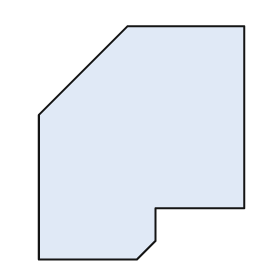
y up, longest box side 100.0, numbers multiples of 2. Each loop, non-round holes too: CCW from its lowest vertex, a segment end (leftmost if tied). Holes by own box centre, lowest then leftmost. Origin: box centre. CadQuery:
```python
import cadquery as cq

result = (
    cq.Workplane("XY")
    .moveTo(-44.0, -50.0)
    .lineTo(-2.0, -50.0)
    .lineTo(6.0, -42.0)
    .lineTo(6.0, -28.0)
    .lineTo(44.0, -28.0)
    .lineTo(44.0, 50.0)
    .lineTo(-6.0, 50.0)
    .lineTo(-44.0, 12.0)
    .close()
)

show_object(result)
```